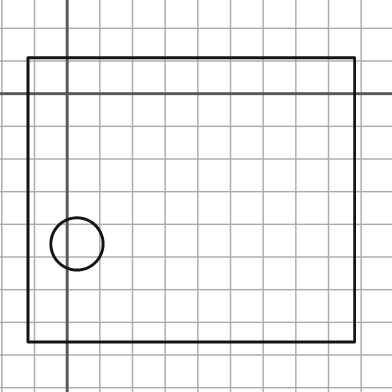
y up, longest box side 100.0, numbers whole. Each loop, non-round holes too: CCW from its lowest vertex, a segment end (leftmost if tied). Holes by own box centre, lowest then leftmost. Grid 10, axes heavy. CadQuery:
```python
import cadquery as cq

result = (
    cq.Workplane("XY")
    .moveTo(-12.0, -76.0)
    .lineTo(88.0, -76.0)
    .lineTo(88.0, 11.0)
    .lineTo(-12.0, 11.0)
    .close()
    .moveTo(3.0, -46.0)
    .circle(8.0)
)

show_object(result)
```